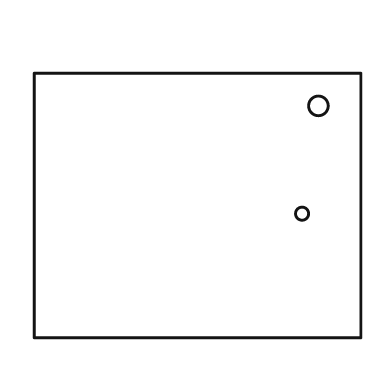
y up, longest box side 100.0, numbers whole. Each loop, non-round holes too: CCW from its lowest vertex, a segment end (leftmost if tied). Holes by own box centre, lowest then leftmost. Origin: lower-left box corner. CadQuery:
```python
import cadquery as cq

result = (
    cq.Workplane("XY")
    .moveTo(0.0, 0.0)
    .lineTo(100.0, 0.0)
    .lineTo(100.0, 81.0)
    .lineTo(0.0, 81.0)
    .close()
    .moveTo(82.0, 38.0)
    .circle(2.0)
    .moveTo(87.0, 71.0)
    .circle(3.0)
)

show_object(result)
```